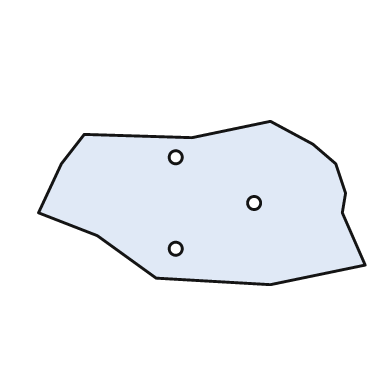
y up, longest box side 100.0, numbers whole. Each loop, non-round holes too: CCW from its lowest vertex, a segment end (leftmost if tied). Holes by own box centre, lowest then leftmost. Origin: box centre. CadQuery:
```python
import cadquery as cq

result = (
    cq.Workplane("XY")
    .moveTo(21.0, -25.0)
    .lineTo(50.0, -19.0)
    .lineTo(43.0, -3.0)
    .lineTo(44.0, 3.0)
    .lineTo(41.0, 12.0)
    .lineTo(34.0, 18.0)
    .lineTo(21.0, 25.0)
    .lineTo(-3.0, 20.0)
    .lineTo(-36.0, 21.0)
    .lineTo(-43.0, 12.0)
    .lineTo(-50.0, -3.0)
    .lineTo(-32.0, -10.0)
    .lineTo(-14.0, -23.0)
    .close()
    .moveTo(-8.0, -14.0)
    .circle(2.0)
    .moveTo(16.0, 0.0)
    .circle(2.0)
    .moveTo(-8.0, 14.0)
    .circle(2.0)
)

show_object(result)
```